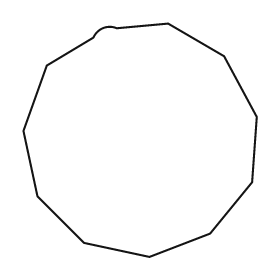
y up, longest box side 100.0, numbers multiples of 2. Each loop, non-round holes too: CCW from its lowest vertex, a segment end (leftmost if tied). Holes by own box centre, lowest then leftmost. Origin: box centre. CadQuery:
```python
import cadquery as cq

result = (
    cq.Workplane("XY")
    .moveTo(4.0, -50.0)
    .lineTo(30.0, -40.0)
    .lineTo(48.0, -18.0)
    .lineTo(50.0, 10.0)
    .lineTo(36.0, 36.0)
    .lineTo(12.0, 50.0)
    .lineTo(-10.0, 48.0)
    .threePointArc((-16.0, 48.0), (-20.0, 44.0))
    .lineTo(-40.0, 32.0)
    .lineTo(-50.0, 4.0)
    .lineTo(-44.0, -24.0)
    .lineTo(-24.0, -44.0)
    .close()
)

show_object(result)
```